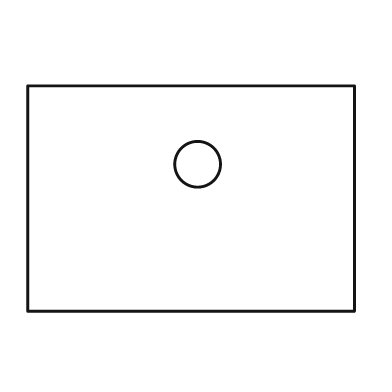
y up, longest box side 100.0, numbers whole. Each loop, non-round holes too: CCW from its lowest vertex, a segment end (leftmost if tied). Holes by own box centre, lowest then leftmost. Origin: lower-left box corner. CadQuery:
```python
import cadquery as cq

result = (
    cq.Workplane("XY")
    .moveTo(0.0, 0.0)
    .lineTo(100.0, 0.0)
    .lineTo(100.0, 69.0)
    .lineTo(0.0, 69.0)
    .close()
    .moveTo(52.0, 45.0)
    .circle(7.0)
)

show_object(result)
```